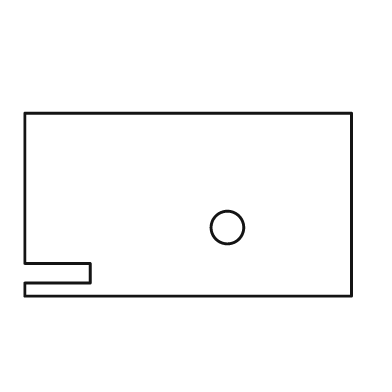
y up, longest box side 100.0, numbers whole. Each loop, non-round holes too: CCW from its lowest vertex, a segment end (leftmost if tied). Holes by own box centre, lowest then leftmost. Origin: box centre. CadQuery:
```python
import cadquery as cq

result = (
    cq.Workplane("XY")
    .moveTo(-50.0, -28.0)
    .lineTo(50.0, -28.0)
    .lineTo(50.0, 28.0)
    .lineTo(-50.0, 28.0)
    .lineTo(-50.0, -18.0)
    .lineTo(-30.0, -18.0)
    .lineTo(-30.0, -24.0)
    .lineTo(-50.0, -24.0)
    .close()
    .moveTo(12.0, -7.0)
    .circle(5.0)
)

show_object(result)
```